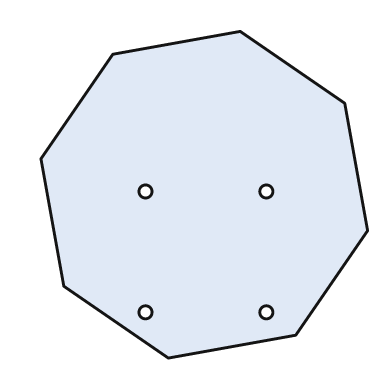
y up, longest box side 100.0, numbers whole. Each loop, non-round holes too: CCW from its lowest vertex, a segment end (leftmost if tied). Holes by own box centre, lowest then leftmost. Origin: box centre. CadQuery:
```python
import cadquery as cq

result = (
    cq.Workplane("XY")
    .moveTo(-11.0, -50.0)
    .lineTo(28.0, -43.0)
    .lineTo(50.0, -11.0)
    .lineTo(43.0, 28.0)
    .lineTo(11.0, 50.0)
    .lineTo(-28.0, 43.0)
    .lineTo(-50.0, 11.0)
    .lineTo(-43.0, -28.0)
    .close()
    .moveTo(-18.0, -36.0)
    .circle(2.0)
    .moveTo(19.0, -36.0)
    .circle(2.0)
    .moveTo(-18.0, 1.0)
    .circle(2.0)
    .moveTo(19.0, 1.0)
    .circle(2.0)
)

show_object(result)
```